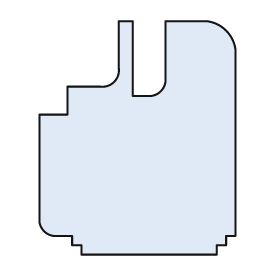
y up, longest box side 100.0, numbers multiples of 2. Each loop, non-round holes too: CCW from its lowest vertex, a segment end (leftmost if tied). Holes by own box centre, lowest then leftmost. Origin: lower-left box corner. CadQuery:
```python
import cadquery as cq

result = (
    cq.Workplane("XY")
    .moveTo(18.0, 0.0)
    .lineTo(76.0, 0.0)
    .lineTo(76.0, 4.0)
    .lineTo(80.0, 4.0)
    .lineTo(80.0, 8.0)
    .lineTo(84.0, 8.0)
    .lineTo(84.0, 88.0)
    .threePointArc((80.0, 96.0), (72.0, 100.0))
    .lineTo(54.0, 100.0)
    .lineTo(54.0, 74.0)
    .threePointArc((52.0, 70.0), (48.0, 68.0))
    .lineTo(40.0, 68.0)
    .lineTo(40.0, 100.0)
    .lineTo(34.0, 100.0)
    .lineTo(34.0, 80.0)
    .threePointArc((32.0, 74.0), (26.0, 72.0))
    .lineTo(12.0, 72.0)
    .lineTo(12.0, 60.0)
    .lineTo(0.0, 60.0)
    .lineTo(0.0, 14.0)
    .threePointArc((2.0, 10.0), (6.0, 8.0))
    .lineTo(14.0, 8.0)
    .lineTo(14.0, 4.0)
    .lineTo(18.0, 4.0)
    .close()
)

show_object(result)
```